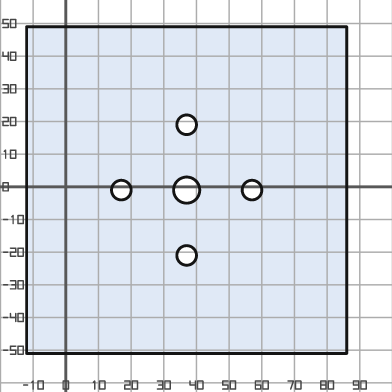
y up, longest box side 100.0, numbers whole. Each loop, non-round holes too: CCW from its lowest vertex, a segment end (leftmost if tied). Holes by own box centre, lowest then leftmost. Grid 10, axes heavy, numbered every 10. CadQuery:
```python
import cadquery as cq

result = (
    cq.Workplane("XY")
    .moveTo(-12.0, -51.0)
    .lineTo(86.0, -51.0)
    .lineTo(86.0, 49.0)
    .lineTo(-12.0, 49.0)
    .close()
    .moveTo(37.0, -21.0)
    .circle(3.0)
    .moveTo(17.0, -1.0)
    .circle(3.0)
    .moveTo(37.0, -1.0)
    .circle(4.0)
    .moveTo(57.0, -1.0)
    .circle(3.0)
    .moveTo(37.0, 19.0)
    .circle(3.0)
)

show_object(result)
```